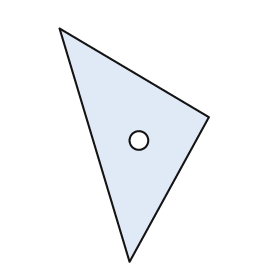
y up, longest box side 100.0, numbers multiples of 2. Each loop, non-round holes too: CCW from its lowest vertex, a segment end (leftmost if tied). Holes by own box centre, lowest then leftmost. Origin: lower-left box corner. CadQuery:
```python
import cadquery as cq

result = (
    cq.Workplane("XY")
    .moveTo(30.0, 0.0)
    .lineTo(64.0, 62.0)
    .lineTo(0.0, 100.0)
    .close()
    .moveTo(34.0, 52.0)
    .circle(4.0)
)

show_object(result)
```